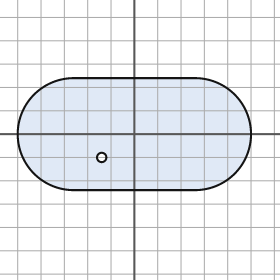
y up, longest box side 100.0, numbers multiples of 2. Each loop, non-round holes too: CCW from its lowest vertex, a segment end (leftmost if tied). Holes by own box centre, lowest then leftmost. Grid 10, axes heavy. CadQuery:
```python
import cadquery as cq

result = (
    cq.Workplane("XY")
    .moveTo(-26.0, -24.0)
    .lineTo(26.0, -24.0)
    .threePointArc((50.0, 0.0), (26.0, 24.0))
    .lineTo(-26.0, 24.0)
    .threePointArc((-50.0, 0.0), (-26.0, -24.0))
    .close()
    .moveTo(-14.0, -10.0)
    .circle(2.0)
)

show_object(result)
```